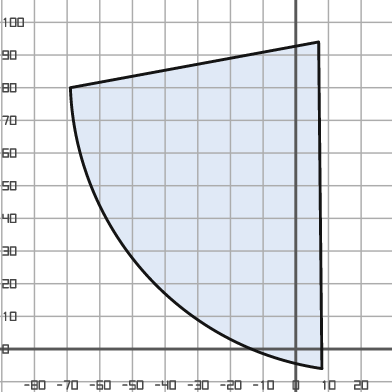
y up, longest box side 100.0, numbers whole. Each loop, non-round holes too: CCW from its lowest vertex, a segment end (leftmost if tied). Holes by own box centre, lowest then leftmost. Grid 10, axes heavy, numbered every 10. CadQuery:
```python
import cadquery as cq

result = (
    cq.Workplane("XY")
    .moveTo(8.0, -6.0)
    .lineTo(7.0, 94.0)
    .lineTo(-69.0, 80.0)
    .threePointArc((-46.0, 23.0), (8.0, -6.0))
    .close()
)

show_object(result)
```